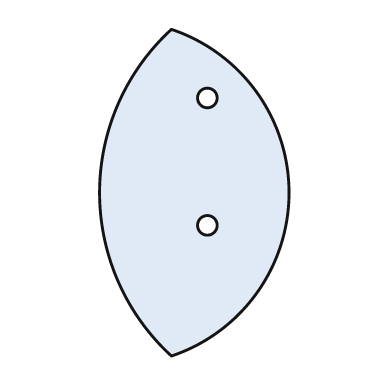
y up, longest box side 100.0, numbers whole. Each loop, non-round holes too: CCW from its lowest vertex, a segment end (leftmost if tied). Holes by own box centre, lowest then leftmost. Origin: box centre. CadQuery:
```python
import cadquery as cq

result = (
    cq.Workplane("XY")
    .moveTo(-7.0, -50.0)
    .threePointArc((29.0, 0.0), (-7.0, 50.0))
    .threePointArc((-29.0, 0.0), (-7.0, -50.0))
    .close()
    .moveTo(4.0, -10.0)
    .circle(3.0)
    .moveTo(4.0, 29.0)
    .circle(3.0)
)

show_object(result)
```